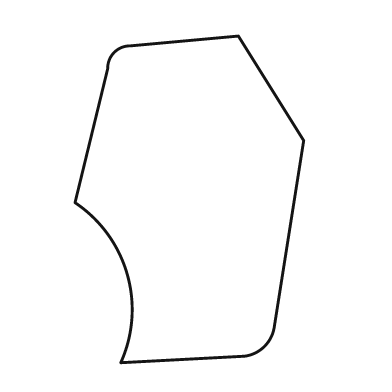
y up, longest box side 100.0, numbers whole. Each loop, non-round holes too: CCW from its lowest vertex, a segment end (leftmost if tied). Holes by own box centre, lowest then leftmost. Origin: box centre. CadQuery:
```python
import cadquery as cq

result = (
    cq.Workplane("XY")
    .moveTo(-21.0, -50.0)
    .lineTo(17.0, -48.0)
    .threePointArc((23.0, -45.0), (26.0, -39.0))
    .lineTo(35.0, 18.0)
    .lineTo(15.0, 50.0)
    .lineTo(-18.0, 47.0)
    .threePointArc((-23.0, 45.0), (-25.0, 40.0))
    .lineTo(-35.0, -1.0)
    .threePointArc((-19.0, -23.0), (-21.0, -50.0))
    .close()
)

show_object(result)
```